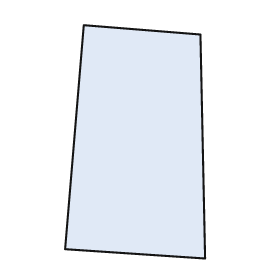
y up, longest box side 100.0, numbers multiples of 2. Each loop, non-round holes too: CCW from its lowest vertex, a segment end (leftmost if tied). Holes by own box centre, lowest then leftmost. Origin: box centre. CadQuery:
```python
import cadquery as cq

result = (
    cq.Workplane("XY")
    .moveTo(30.0, -50.0)
    .lineTo(28.0, 46.0)
    .lineTo(-22.0, 50.0)
    .lineTo(-30.0, -46.0)
    .close()
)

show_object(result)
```